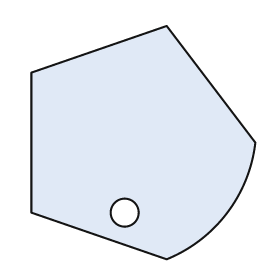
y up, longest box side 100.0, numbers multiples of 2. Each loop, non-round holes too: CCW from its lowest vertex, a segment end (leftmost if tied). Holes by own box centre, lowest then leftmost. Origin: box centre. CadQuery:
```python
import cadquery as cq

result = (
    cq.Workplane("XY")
    .moveTo(10.0, -50.0)
    .threePointArc((36.0, -30.0), (48.0, 0.0))
    .lineTo(10.0, 50.0)
    .lineTo(-48.0, 30.0)
    .lineTo(-48.0, -30.0)
    .close()
    .moveTo(-8.0, -30.0)
    .circle(6.0)
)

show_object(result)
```